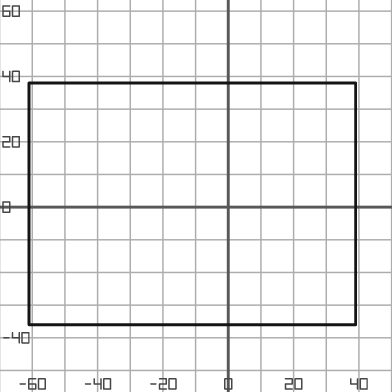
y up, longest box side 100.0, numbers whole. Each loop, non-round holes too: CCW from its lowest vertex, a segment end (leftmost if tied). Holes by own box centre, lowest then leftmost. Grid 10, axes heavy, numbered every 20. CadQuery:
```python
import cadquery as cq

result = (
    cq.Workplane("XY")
    .moveTo(-61.0, -36.0)
    .lineTo(39.0, -36.0)
    .lineTo(39.0, 38.0)
    .lineTo(-61.0, 38.0)
    .close()
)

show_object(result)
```